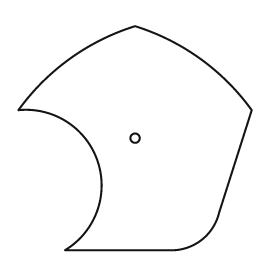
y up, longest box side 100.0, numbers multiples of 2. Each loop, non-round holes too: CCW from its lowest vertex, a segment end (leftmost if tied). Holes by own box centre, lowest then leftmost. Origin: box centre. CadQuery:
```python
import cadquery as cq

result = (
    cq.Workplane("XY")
    .moveTo(-30.0, -48.0)
    .lineTo(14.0, -48.0)
    .threePointArc((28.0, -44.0), (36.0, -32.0))
    .lineTo(50.0, 12.0)
    .threePointArc((28.0, 34.0), (0.0, 48.0))
    .threePointArc((-28.0, 34.0), (-50.0, 12.0))
    .threePointArc((-16.0, -10.0), (-30.0, -48.0))
    .close()
    .moveTo(0.0, 0.0)
    .circle(2.0)
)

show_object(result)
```